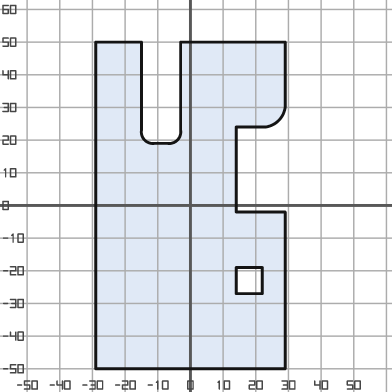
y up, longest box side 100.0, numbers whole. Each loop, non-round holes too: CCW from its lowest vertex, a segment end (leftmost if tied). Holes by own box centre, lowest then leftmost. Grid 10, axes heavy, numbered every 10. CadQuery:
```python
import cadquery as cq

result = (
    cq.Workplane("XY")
    .moveTo(-29.0, -50.0)
    .lineTo(29.0, -50.0)
    .lineTo(29.0, -2.0)
    .lineTo(14.0, -2.0)
    .lineTo(14.0, 24.0)
    .lineTo(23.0, 24.0)
    .threePointArc((27.0, 26.0), (29.0, 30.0))
    .lineTo(29.0, 50.0)
    .lineTo(-3.0, 50.0)
    .lineTo(-3.0, 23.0)
    .threePointArc((-4.0, 20.0), (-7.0, 19.0))
    .lineTo(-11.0, 19.0)
    .threePointArc((-14.0, 20.0), (-15.0, 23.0))
    .lineTo(-15.0, 50.0)
    .lineTo(-29.0, 50.0)
    .close()
    .moveTo(14.0, -27.0)
    .lineTo(22.0, -27.0)
    .lineTo(22.0, -19.0)
    .lineTo(14.0, -19.0)
    .close()
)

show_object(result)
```